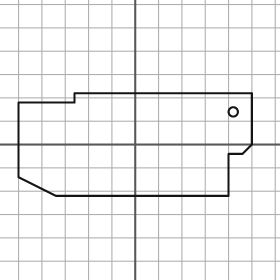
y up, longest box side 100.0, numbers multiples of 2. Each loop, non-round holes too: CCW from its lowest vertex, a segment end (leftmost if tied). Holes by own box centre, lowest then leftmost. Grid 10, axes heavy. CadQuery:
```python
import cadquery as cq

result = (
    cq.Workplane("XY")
    .moveTo(-34.0, -22.0)
    .lineTo(40.0, -22.0)
    .lineTo(40.0, -4.0)
    .lineTo(46.0, -4.0)
    .lineTo(50.0, 0.0)
    .lineTo(50.0, 22.0)
    .lineTo(-26.0, 22.0)
    .lineTo(-26.0, 18.0)
    .lineTo(-50.0, 18.0)
    .lineTo(-50.0, -14.0)
    .close()
    .moveTo(42.0, 14.0)
    .circle(2.0)
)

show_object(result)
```